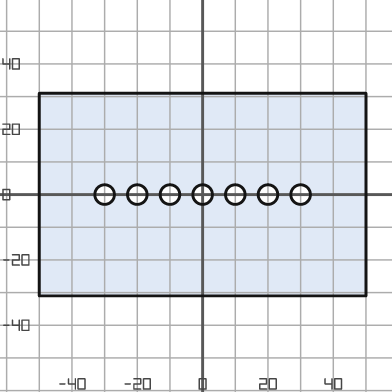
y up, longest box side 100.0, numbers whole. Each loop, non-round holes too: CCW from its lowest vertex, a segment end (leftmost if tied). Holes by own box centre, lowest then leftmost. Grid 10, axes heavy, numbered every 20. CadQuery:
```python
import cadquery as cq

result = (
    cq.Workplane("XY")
    .moveTo(-50.0, -31.0)
    .lineTo(50.0, -31.0)
    .lineTo(50.0, 31.0)
    .lineTo(-50.0, 31.0)
    .close()
    .moveTo(-30.0, 0.0)
    .circle(3.0)
    .moveTo(-20.0, 0.0)
    .circle(3.0)
    .moveTo(-10.0, 0.0)
    .circle(3.0)
    .moveTo(0.0, 0.0)
    .circle(3.0)
    .moveTo(10.0, 0.0)
    .circle(3.0)
    .moveTo(20.0, 0.0)
    .circle(3.0)
    .moveTo(30.0, 0.0)
    .circle(3.0)
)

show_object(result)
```